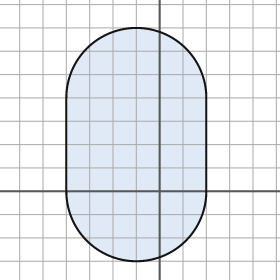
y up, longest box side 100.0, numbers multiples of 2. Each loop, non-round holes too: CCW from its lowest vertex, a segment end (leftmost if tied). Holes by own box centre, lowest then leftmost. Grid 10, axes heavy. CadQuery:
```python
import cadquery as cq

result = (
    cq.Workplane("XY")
    .moveTo(-40.0, 0.0)
    .threePointArc((-10.0, -30.0), (20.0, 0.0))
    .lineTo(20.0, 40.0)
    .threePointArc((-10.0, 70.0), (-40.0, 40.0))
    .close()
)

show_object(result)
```